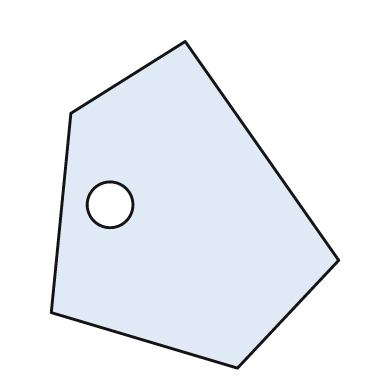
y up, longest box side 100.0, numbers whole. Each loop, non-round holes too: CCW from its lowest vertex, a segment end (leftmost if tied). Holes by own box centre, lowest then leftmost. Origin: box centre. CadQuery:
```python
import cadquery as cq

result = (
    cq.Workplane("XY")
    .moveTo(13.0, -50.0)
    .lineTo(44.0, -17.0)
    .lineTo(-3.0, 50.0)
    .lineTo(-38.0, 28.0)
    .lineTo(-44.0, -33.0)
    .close()
    .moveTo(-26.0, 0.0)
    .circle(7.0)
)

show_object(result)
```